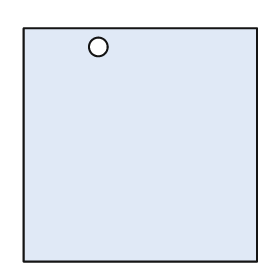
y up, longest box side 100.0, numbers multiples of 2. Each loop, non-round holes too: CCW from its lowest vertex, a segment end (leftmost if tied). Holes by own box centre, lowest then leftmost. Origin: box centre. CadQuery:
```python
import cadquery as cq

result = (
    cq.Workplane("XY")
    .moveTo(-50.0, -50.0)
    .lineTo(50.0, -50.0)
    .lineTo(50.0, 50.0)
    .lineTo(-50.0, 50.0)
    .close()
    .moveTo(-18.0, 42.0)
    .circle(4.0)
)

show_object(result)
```